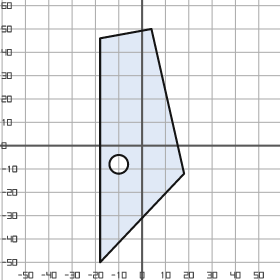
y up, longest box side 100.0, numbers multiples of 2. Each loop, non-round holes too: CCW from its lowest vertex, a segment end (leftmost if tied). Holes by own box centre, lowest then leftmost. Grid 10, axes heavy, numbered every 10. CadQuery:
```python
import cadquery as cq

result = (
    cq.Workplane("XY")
    .moveTo(-18.0, -50.0)
    .lineTo(18.0, -12.0)
    .lineTo(4.0, 50.0)
    .lineTo(-18.0, 46.0)
    .close()
    .moveTo(-10.0, -8.0)
    .circle(4.0)
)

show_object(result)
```